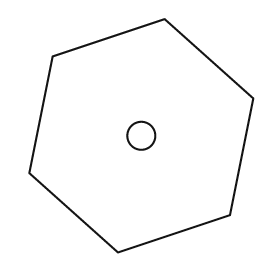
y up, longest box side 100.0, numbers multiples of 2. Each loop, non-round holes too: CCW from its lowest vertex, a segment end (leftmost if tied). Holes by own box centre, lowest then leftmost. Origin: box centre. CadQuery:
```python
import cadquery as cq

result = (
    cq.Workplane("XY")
    .moveTo(-10.0, -50.0)
    .lineTo(38.0, -34.0)
    .lineTo(48.0, 16.0)
    .lineTo(10.0, 50.0)
    .lineTo(-38.0, 34.0)
    .lineTo(-48.0, -16.0)
    .close()
    .moveTo(0.0, 0.0)
    .circle(6.0)
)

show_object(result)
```